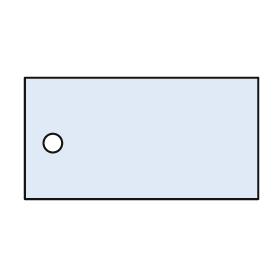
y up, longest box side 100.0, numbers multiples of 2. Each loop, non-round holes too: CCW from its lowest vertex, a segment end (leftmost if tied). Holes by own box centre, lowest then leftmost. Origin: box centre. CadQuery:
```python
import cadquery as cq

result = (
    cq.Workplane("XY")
    .moveTo(-50.0, -26.0)
    .lineTo(50.0, -26.0)
    .lineTo(50.0, 26.0)
    .lineTo(-50.0, 26.0)
    .close()
    .moveTo(-38.0, -2.0)
    .circle(4.0)
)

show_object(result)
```